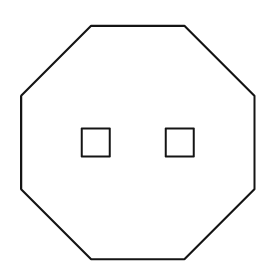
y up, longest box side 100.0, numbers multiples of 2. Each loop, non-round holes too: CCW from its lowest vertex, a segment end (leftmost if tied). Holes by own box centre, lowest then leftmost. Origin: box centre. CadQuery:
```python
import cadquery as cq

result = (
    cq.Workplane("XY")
    .moveTo(-20.0, -50.0)
    .lineTo(20.0, -50.0)
    .lineTo(50.0, -20.0)
    .lineTo(50.0, 20.0)
    .lineTo(20.0, 50.0)
    .lineTo(-20.0, 50.0)
    .lineTo(-50.0, 20.0)
    .lineTo(-50.0, -20.0)
    .close()
    .moveTo(-24.0, -6.0)
    .lineTo(-12.0, -6.0)
    .lineTo(-12.0, 6.0)
    .lineTo(-24.0, 6.0)
    .close()
    .moveTo(12.0, -6.0)
    .lineTo(24.0, -6.0)
    .lineTo(24.0, 6.0)
    .lineTo(12.0, 6.0)
    .close()
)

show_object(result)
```